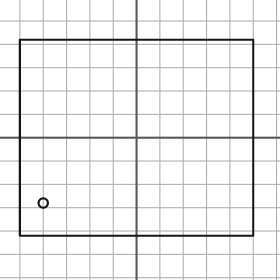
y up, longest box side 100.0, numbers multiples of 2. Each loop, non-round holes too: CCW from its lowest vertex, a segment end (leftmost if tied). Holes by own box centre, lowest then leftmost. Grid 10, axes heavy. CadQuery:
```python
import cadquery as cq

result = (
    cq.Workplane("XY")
    .moveTo(-50.0, -42.0)
    .lineTo(50.0, -42.0)
    .lineTo(50.0, 42.0)
    .lineTo(-50.0, 42.0)
    .close()
    .moveTo(-40.0, -28.0)
    .circle(2.0)
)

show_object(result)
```